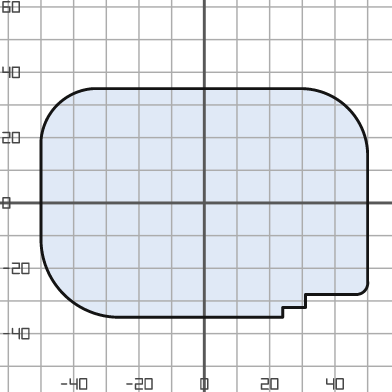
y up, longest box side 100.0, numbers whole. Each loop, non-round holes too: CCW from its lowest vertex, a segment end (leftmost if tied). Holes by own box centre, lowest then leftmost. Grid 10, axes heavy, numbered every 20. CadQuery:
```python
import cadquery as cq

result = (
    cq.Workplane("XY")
    .moveTo(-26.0, -35.0)
    .lineTo(24.0, -35.0)
    .lineTo(24.0, -32.0)
    .lineTo(31.0, -32.0)
    .lineTo(31.0, -28.0)
    .lineTo(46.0, -28.0)
    .threePointArc((49.0, -27.0), (50.0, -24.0))
    .lineTo(50.0, 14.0)
    .threePointArc((44.0, 29.0), (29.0, 35.0))
    .lineTo(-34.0, 35.0)
    .threePointArc((-45.0, 30.0), (-50.0, 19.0))
    .lineTo(-50.0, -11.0)
    .threePointArc((-43.0, -28.0), (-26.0, -35.0))
    .close()
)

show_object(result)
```